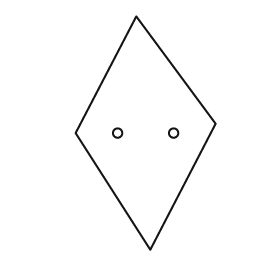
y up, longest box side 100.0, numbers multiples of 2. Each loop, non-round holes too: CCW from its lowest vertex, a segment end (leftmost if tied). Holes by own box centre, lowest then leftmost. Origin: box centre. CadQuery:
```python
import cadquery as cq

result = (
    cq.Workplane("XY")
    .moveTo(2.0, -50.0)
    .lineTo(30.0, 4.0)
    .lineTo(-4.0, 50.0)
    .lineTo(-30.0, 0.0)
    .close()
    .moveTo(-12.0, 0.0)
    .circle(2.0)
    .moveTo(12.0, 0.0)
    .circle(2.0)
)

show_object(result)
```